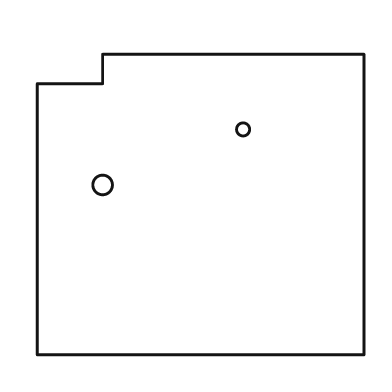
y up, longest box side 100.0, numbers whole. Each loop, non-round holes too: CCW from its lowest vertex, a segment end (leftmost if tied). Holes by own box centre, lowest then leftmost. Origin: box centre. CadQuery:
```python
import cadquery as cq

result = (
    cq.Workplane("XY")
    .moveTo(-50.0, -46.0)
    .lineTo(50.0, -46.0)
    .lineTo(50.0, 46.0)
    .lineTo(-30.0, 46.0)
    .lineTo(-30.0, 37.0)
    .lineTo(-50.0, 37.0)
    .close()
    .moveTo(-30.0, 6.0)
    .circle(3.0)
    .moveTo(13.0, 23.0)
    .circle(2.0)
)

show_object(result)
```